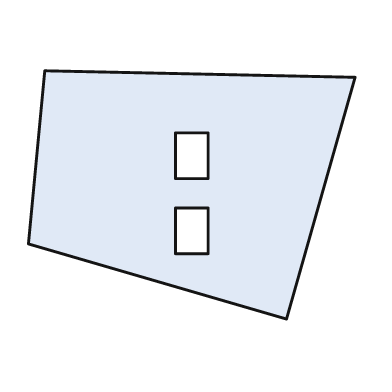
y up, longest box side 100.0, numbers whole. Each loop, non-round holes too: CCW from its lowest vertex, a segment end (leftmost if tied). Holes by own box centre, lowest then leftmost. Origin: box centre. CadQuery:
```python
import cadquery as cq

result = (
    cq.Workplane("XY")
    .moveTo(29.0, -38.0)
    .lineTo(50.0, 36.0)
    .lineTo(-45.0, 38.0)
    .lineTo(-50.0, -15.0)
    .close()
    .moveTo(-5.0, -18.0)
    .lineTo(5.0, -18.0)
    .lineTo(5.0, -4.0)
    .lineTo(-5.0, -4.0)
    .close()
    .moveTo(-5.0, 5.0)
    .lineTo(5.0, 5.0)
    .lineTo(5.0, 19.0)
    .lineTo(-5.0, 19.0)
    .close()
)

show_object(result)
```